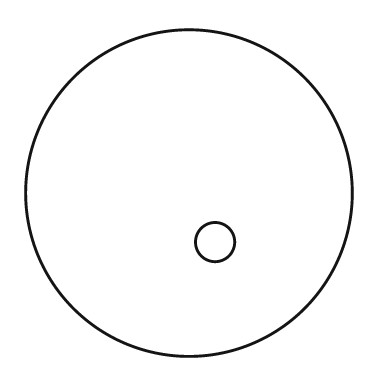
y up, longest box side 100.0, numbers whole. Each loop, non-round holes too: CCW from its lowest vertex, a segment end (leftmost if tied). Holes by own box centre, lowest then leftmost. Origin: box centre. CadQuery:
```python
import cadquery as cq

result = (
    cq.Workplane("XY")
    .moveTo(0.0, 0.0)
    .circle(50.0)
    .moveTo(8.0, -15.0)
    .circle(6.0)
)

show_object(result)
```